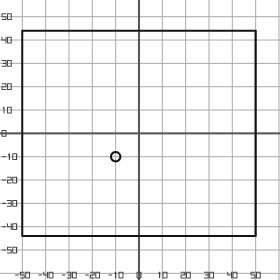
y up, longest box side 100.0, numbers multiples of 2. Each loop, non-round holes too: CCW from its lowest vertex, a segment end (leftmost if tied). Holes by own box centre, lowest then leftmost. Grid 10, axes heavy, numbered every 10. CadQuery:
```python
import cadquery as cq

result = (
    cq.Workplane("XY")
    .moveTo(-50.0, -44.0)
    .lineTo(50.0, -44.0)
    .lineTo(50.0, 44.0)
    .lineTo(-50.0, 44.0)
    .close()
    .moveTo(-10.0, -10.0)
    .circle(2.0)
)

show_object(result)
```